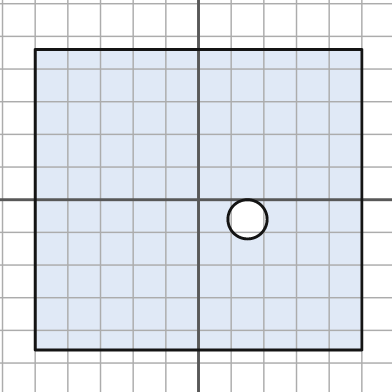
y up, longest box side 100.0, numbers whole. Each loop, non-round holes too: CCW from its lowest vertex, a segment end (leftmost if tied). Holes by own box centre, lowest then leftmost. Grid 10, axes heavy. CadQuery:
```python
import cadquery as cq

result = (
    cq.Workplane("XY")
    .moveTo(-50.0, -46.0)
    .lineTo(50.0, -46.0)
    .lineTo(50.0, 46.0)
    .lineTo(-50.0, 46.0)
    .close()
    .moveTo(15.0, -6.0)
    .circle(6.0)
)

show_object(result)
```